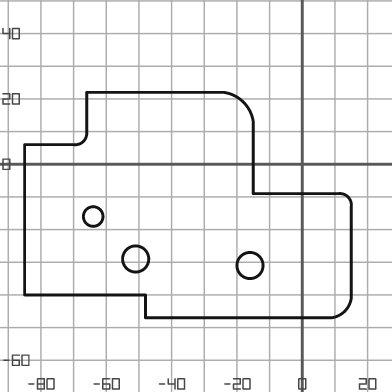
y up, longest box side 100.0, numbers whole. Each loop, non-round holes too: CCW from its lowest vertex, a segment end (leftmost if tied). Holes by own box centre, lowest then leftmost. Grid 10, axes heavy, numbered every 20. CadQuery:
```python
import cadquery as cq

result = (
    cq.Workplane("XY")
    .moveTo(-48.0, -47.0)
    .lineTo(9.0, -47.0)
    .threePointArc((13.0, -45.0), (15.0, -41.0))
    .lineTo(15.0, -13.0)
    .threePointArc((14.0, -10.0), (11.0, -9.0))
    .lineTo(-15.0, -9.0)
    .lineTo(-15.0, 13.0)
    .threePointArc((-18.0, 19.0), (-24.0, 22.0))
    .lineTo(-66.0, 22.0)
    .lineTo(-66.0, 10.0)
    .threePointArc((-67.0, 7.0), (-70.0, 6.0))
    .lineTo(-85.0, 6.0)
    .lineTo(-85.0, -40.0)
    .lineTo(-48.0, -40.0)
    .close()
    .moveTo(-16.0, -31.0)
    .circle(4.0)
    .moveTo(-51.0, -29.0)
    .circle(4.0)
    .moveTo(-64.0, -16.0)
    .circle(3.0)
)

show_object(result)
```